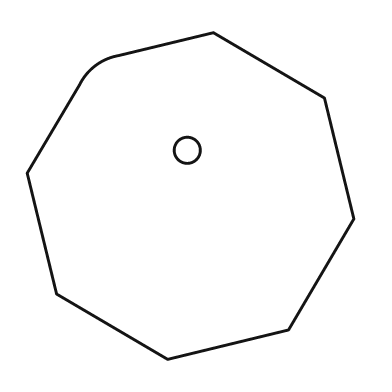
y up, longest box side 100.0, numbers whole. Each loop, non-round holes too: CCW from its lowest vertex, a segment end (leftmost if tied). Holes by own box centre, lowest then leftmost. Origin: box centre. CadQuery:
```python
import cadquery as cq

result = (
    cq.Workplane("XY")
    .moveTo(-7.0, -50.0)
    .lineTo(30.0, -41.0)
    .lineTo(50.0, -7.0)
    .lineTo(41.0, 30.0)
    .lineTo(7.0, 50.0)
    .lineTo(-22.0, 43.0)
    .threePointArc((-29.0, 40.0), (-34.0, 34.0))
    .lineTo(-50.0, 7.0)
    .lineTo(-41.0, -30.0)
    .close()
    .moveTo(-1.0, 14.0)
    .circle(4.0)
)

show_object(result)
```